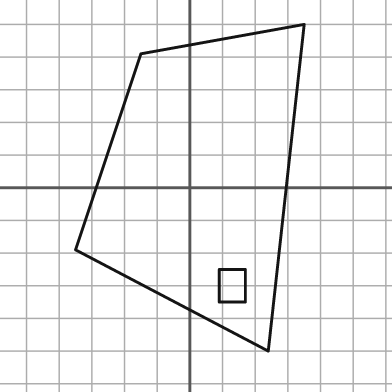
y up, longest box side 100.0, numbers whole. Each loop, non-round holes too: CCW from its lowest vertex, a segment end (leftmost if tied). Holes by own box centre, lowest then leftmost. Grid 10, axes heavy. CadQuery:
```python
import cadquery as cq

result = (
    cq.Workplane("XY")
    .moveTo(24.0, -50.0)
    .lineTo(35.0, 50.0)
    .lineTo(-15.0, 41.0)
    .lineTo(-35.0, -19.0)
    .close()
    .moveTo(9.0, -35.0)
    .lineTo(17.0, -35.0)
    .lineTo(17.0, -25.0)
    .lineTo(9.0, -25.0)
    .close()
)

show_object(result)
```